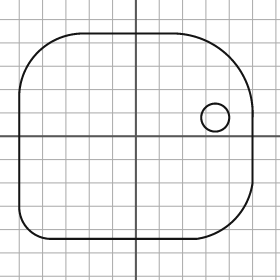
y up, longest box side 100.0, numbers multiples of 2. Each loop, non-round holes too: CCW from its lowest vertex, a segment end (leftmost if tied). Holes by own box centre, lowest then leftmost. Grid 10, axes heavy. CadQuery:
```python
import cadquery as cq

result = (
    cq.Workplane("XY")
    .moveTo(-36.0, -44.0)
    .lineTo(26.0, -44.0)
    .threePointArc((42.0, -36.0), (50.0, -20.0))
    .lineTo(50.0, 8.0)
    .threePointArc((40.0, 34.0), (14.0, 44.0))
    .lineTo(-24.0, 44.0)
    .threePointArc((-42.0, 36.0), (-50.0, 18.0))
    .lineTo(-50.0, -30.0)
    .threePointArc((-46.0, -40.0), (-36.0, -44.0))
    .close()
    .moveTo(34.0, 8.0)
    .circle(6.0)
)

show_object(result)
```